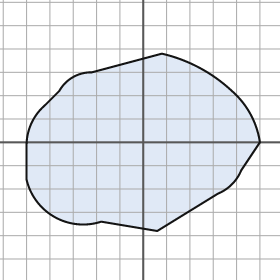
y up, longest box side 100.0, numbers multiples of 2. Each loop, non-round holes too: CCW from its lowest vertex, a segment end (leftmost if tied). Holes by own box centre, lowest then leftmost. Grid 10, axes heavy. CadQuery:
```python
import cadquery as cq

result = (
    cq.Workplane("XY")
    .moveTo(6.0, -38.0)
    .lineTo(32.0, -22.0)
    .threePointArc((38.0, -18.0), (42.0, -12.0))
    .lineTo(50.0, 0.0)
    .threePointArc((46.0, 12.0), (38.0, 22.0))
    .threePointArc((24.0, 32.0), (8.0, 38.0))
    .lineTo(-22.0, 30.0)
    .threePointArc((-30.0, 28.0), (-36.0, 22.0))
    .lineTo(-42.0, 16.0)
    .threePointArc((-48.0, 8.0), (-50.0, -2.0))
    .lineTo(-50.0, -16.0)
    .threePointArc((-38.0, -32.0), (-18.0, -34.0))
    .close()
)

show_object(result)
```